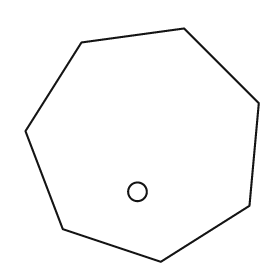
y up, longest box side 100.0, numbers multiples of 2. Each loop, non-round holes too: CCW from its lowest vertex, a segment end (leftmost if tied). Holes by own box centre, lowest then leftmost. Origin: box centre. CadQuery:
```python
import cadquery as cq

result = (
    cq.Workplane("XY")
    .moveTo(8.0, -50.0)
    .lineTo(46.0, -26.0)
    .lineTo(50.0, 18.0)
    .lineTo(18.0, 50.0)
    .lineTo(-26.0, 44.0)
    .lineTo(-50.0, 6.0)
    .lineTo(-34.0, -36.0)
    .close()
    .moveTo(-2.0, -20.0)
    .circle(4.0)
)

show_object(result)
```